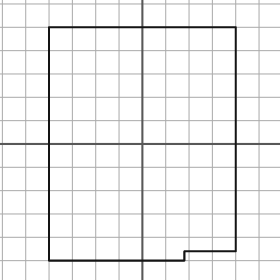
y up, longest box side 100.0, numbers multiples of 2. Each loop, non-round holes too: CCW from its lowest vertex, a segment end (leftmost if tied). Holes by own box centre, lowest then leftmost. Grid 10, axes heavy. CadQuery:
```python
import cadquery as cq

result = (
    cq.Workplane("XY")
    .moveTo(-40.0, -50.0)
    .lineTo(18.0, -50.0)
    .lineTo(18.0, -46.0)
    .lineTo(40.0, -46.0)
    .lineTo(40.0, 50.0)
    .lineTo(-40.0, 50.0)
    .close()
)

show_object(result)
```